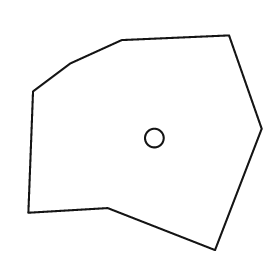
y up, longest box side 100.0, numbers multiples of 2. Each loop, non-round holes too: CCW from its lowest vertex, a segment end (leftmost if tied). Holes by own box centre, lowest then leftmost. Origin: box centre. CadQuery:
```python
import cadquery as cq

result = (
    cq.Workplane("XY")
    .moveTo(30.0, -46.0)
    .lineTo(50.0, 6.0)
    .lineTo(36.0, 46.0)
    .lineTo(-10.0, 44.0)
    .lineTo(-32.0, 34.0)
    .lineTo(-48.0, 22.0)
    .lineTo(-50.0, -30.0)
    .lineTo(-16.0, -28.0)
    .close()
    .moveTo(4.0, 2.0)
    .circle(4.0)
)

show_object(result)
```